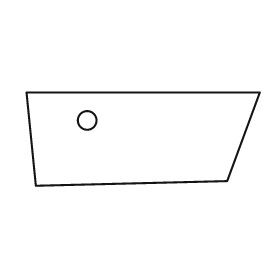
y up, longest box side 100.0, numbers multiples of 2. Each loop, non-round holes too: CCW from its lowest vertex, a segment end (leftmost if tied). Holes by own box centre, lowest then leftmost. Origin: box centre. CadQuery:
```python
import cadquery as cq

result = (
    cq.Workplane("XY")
    .moveTo(-46.0, -20.0)
    .lineTo(36.0, -18.0)
    .lineTo(50.0, 20.0)
    .lineTo(-50.0, 20.0)
    .close()
    .moveTo(-24.0, 8.0)
    .circle(4.0)
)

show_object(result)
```